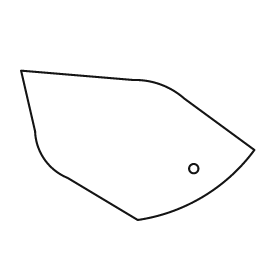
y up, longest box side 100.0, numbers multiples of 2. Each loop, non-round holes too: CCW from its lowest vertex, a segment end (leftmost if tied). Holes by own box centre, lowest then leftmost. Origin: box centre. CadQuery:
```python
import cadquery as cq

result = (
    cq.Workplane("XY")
    .moveTo(0.0, -32.0)
    .threePointArc((28.0, -22.0), (50.0, -2.0))
    .lineTo(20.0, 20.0)
    .threePointArc((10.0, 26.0), (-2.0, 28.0))
    .lineTo(-50.0, 32.0)
    .lineTo(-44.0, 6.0)
    .threePointArc((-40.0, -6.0), (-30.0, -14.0))
    .close()
    .moveTo(24.0, -10.0)
    .circle(2.0)
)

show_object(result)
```